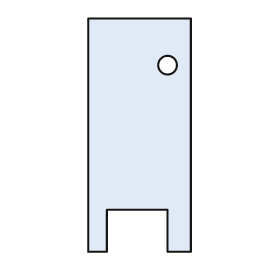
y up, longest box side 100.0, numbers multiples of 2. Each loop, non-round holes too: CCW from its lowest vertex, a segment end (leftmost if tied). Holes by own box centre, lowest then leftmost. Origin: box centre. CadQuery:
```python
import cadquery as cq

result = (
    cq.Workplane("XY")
    .moveTo(-22.0, -50.0)
    .lineTo(-14.0, -50.0)
    .lineTo(-14.0, -32.0)
    .lineTo(12.0, -32.0)
    .lineTo(12.0, -50.0)
    .lineTo(22.0, -50.0)
    .lineTo(22.0, 50.0)
    .lineTo(-22.0, 50.0)
    .close()
    .moveTo(12.0, 30.0)
    .circle(4.0)
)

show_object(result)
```